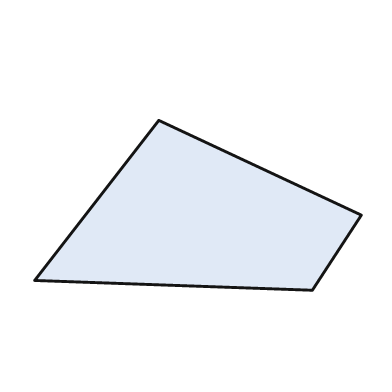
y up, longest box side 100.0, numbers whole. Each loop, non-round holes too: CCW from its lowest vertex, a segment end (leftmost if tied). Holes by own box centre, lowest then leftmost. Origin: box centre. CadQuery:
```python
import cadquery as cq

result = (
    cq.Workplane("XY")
    .moveTo(35.0, -26.0)
    .lineTo(50.0, -3.0)
    .lineTo(-12.0, 26.0)
    .lineTo(-50.0, -23.0)
    .close()
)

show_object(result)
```